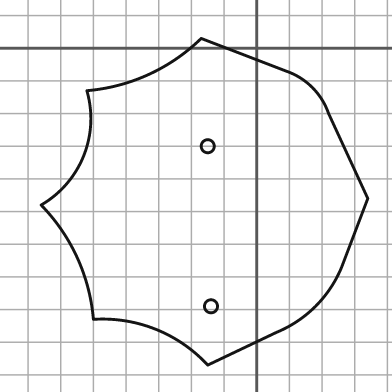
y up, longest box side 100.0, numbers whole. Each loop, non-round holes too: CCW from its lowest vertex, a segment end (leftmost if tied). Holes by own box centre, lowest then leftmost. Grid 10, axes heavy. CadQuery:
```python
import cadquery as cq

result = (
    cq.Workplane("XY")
    .moveTo(-15.0, -97.0)
    .lineTo(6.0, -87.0)
    .threePointArc((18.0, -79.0), (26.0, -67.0))
    .lineTo(34.0, -46.0)
    .lineTo(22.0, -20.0)
    .threePointArc((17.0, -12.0), (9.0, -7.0))
    .lineTo(-17.0, 3.0)
    .threePointArc((-33.0, -8.0), (-52.0, -13.0))
    .threePointArc((-53.0, -33.0), (-66.0, -48.0))
    .threePointArc((-55.0, -64.0), (-50.0, -83.0))
    .threePointArc((-31.0, -86.0), (-15.0, -97.0))
    .close()
    .moveTo(-14.0, -79.0)
    .circle(2.0)
    .moveTo(-15.0, -30.0)
    .circle(2.0)
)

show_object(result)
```